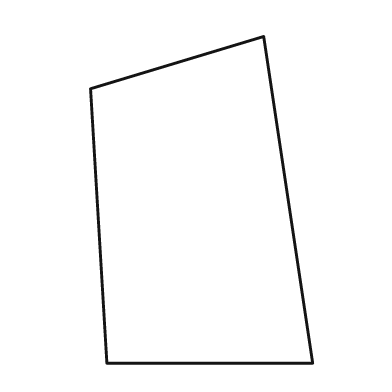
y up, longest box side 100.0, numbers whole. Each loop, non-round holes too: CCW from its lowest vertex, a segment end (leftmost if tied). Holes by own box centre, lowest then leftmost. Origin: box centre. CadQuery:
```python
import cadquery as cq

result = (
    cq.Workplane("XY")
    .moveTo(-29.0, -50.0)
    .lineTo(34.0, -50.0)
    .lineTo(19.0, 50.0)
    .lineTo(-34.0, 34.0)
    .close()
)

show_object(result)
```